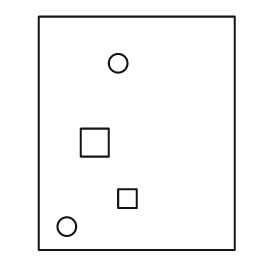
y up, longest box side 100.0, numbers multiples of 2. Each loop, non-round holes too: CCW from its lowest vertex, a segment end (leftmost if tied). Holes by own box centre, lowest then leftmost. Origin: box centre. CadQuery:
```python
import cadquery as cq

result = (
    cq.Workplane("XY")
    .moveTo(-42.0, -50.0)
    .lineTo(42.0, -50.0)
    .lineTo(42.0, 50.0)
    .lineTo(-42.0, 50.0)
    .close()
    .moveTo(-30.0, -40.0)
    .circle(4.0)
    .moveTo(-8.0, -32.0)
    .lineTo(0.0, -32.0)
    .lineTo(0.0, -24.0)
    .lineTo(-8.0, -24.0)
    .close()
    .moveTo(-24.0, -10.0)
    .lineTo(-12.0, -10.0)
    .lineTo(-12.0, 2.0)
    .lineTo(-24.0, 2.0)
    .close()
    .moveTo(-8.0, 30.0)
    .circle(4.0)
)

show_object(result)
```